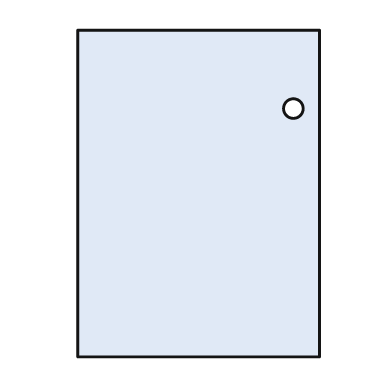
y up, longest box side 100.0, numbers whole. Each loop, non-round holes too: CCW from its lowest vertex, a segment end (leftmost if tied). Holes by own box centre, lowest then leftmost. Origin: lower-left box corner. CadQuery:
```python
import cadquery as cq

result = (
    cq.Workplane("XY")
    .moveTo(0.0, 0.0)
    .lineTo(74.0, 0.0)
    .lineTo(74.0, 100.0)
    .lineTo(0.0, 100.0)
    .close()
    .moveTo(66.0, 76.0)
    .circle(3.0)
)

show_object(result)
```